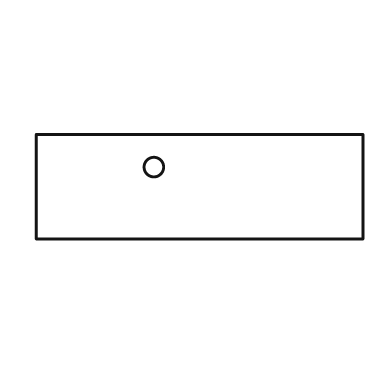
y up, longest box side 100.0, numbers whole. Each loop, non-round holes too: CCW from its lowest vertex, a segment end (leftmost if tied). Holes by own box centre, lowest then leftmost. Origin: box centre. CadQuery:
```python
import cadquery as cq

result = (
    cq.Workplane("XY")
    .moveTo(-50.0, -16.0)
    .lineTo(50.0, -16.0)
    .lineTo(50.0, 16.0)
    .lineTo(-50.0, 16.0)
    .close()
    .moveTo(-14.0, 6.0)
    .circle(3.0)
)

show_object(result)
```